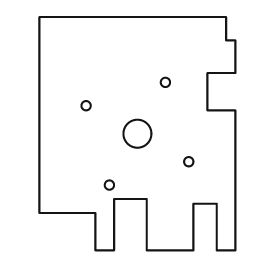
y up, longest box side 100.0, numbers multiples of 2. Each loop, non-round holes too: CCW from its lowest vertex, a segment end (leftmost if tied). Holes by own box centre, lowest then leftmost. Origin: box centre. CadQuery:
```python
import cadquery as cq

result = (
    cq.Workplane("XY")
    .moveTo(-18.0, -50.0)
    .lineTo(-10.0, -50.0)
    .lineTo(-10.0, -28.0)
    .lineTo(4.0, -28.0)
    .lineTo(4.0, -50.0)
    .lineTo(24.0, -50.0)
    .lineTo(24.0, -30.0)
    .lineTo(34.0, -30.0)
    .lineTo(34.0, -50.0)
    .lineTo(42.0, -50.0)
    .lineTo(42.0, 10.0)
    .lineTo(30.0, 10.0)
    .lineTo(30.0, 26.0)
    .lineTo(42.0, 26.0)
    .lineTo(42.0, 40.0)
    .lineTo(38.0, 40.0)
    .lineTo(38.0, 50.0)
    .lineTo(-42.0, 50.0)
    .lineTo(-42.0, -34.0)
    .lineTo(-18.0, -34.0)
    .close()
    .moveTo(-12.0, -22.0)
    .circle(2.0)
    .moveTo(22.0, -12.0)
    .circle(2.0)
    .moveTo(0.0, 0.0)
    .circle(6.0)
    .moveTo(-22.0, 12.0)
    .circle(2.0)
    .moveTo(12.0, 22.0)
    .circle(2.0)
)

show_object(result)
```